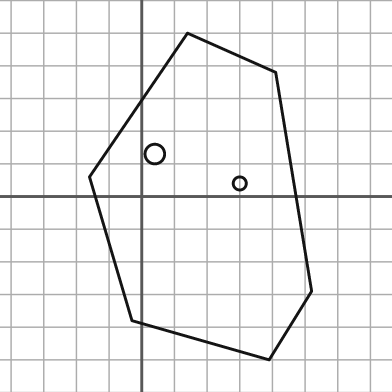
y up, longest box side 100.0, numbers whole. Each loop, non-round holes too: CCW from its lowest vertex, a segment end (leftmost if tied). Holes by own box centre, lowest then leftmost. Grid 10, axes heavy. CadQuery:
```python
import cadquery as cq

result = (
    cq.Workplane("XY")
    .moveTo(39.0, -50.0)
    .lineTo(52.0, -29.0)
    .lineTo(41.0, 38.0)
    .lineTo(14.0, 50.0)
    .lineTo(-16.0, 6.0)
    .lineTo(-3.0, -38.0)
    .close()
    .moveTo(30.0, 4.0)
    .circle(2.0)
    .moveTo(4.0, 13.0)
    .circle(3.0)
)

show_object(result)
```